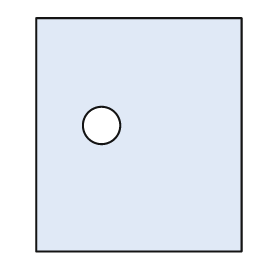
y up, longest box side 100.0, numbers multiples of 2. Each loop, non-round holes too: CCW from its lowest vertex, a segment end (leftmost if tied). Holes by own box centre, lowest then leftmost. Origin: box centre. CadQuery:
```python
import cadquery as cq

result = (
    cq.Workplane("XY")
    .moveTo(-44.0, -50.0)
    .lineTo(44.0, -50.0)
    .lineTo(44.0, 50.0)
    .lineTo(-44.0, 50.0)
    .close()
    .moveTo(-16.0, 4.0)
    .circle(8.0)
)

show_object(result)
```